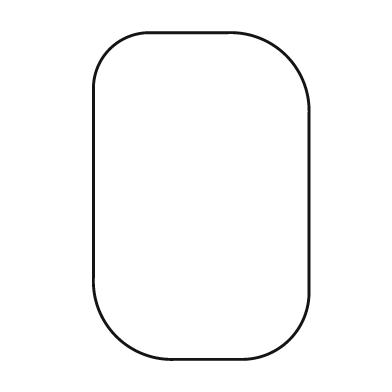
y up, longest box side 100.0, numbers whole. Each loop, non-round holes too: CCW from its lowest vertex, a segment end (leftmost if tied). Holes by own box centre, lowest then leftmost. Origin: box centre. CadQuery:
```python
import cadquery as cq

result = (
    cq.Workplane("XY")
    .moveTo(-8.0, -50.0)
    .lineTo(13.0, -50.0)
    .threePointArc((27.0, -44.0), (33.0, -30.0))
    .lineTo(33.0, 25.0)
    .threePointArc((26.0, 43.0), (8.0, 50.0))
    .lineTo(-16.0, 50.0)
    .threePointArc((-28.0, 45.0), (-33.0, 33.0))
    .lineTo(-33.0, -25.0)
    .threePointArc((-26.0, -43.0), (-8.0, -50.0))
    .close()
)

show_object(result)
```